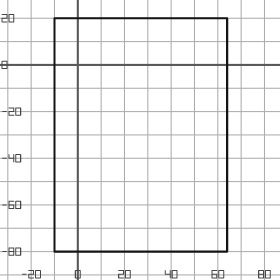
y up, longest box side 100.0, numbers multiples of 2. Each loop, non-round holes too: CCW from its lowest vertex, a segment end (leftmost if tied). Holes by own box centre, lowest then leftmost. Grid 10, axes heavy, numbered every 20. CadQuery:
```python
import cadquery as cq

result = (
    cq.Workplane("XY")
    .moveTo(-10.0, -80.0)
    .lineTo(64.0, -80.0)
    .lineTo(64.0, 20.0)
    .lineTo(-10.0, 20.0)
    .close()
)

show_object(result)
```